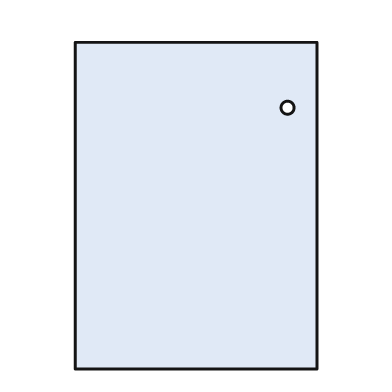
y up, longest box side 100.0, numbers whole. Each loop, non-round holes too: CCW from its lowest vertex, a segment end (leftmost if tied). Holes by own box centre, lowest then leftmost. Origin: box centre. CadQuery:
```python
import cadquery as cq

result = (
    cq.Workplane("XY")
    .moveTo(-37.0, -50.0)
    .lineTo(37.0, -50.0)
    .lineTo(37.0, 50.0)
    .lineTo(-37.0, 50.0)
    .close()
    .moveTo(28.0, 30.0)
    .circle(2.0)
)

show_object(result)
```